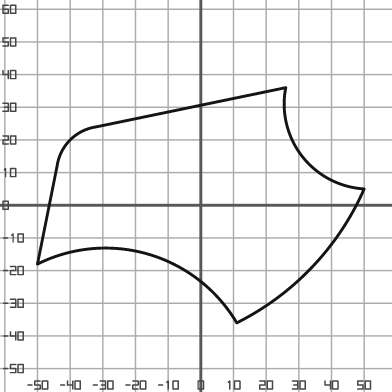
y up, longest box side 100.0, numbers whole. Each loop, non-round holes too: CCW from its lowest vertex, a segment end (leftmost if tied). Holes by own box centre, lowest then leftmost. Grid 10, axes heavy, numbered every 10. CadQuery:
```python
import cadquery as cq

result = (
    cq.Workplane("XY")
    .moveTo(11.0, -36.0)
    .threePointArc((34.0, -19.0), (50.0, 5.0))
    .threePointArc((31.0, 15.0), (26.0, 36.0))
    .lineTo(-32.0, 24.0)
    .threePointArc((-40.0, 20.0), (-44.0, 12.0))
    .lineTo(-50.0, -18.0)
    .threePointArc((-16.0, -15.0), (11.0, -36.0))
    .close()
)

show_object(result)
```